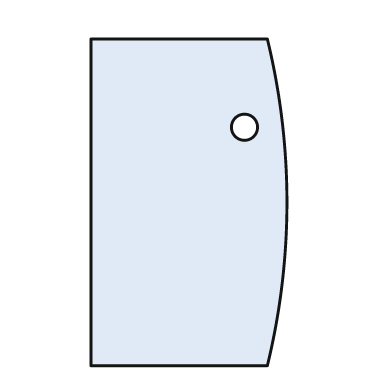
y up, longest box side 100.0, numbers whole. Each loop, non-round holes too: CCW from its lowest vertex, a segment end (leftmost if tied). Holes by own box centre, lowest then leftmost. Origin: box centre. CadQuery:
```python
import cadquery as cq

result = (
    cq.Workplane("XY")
    .moveTo(-30.0, -50.0)
    .lineTo(24.0, -50.0)
    .threePointArc((30.0, 0.0), (24.0, 50.0))
    .lineTo(-30.0, 50.0)
    .close()
    .moveTo(17.0, 23.0)
    .circle(4.0)
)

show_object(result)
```